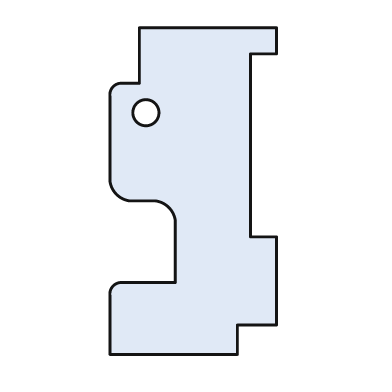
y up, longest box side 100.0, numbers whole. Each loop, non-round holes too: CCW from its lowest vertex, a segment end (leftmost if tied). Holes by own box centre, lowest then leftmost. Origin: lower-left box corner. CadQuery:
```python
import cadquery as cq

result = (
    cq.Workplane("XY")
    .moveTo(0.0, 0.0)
    .lineTo(39.0, 0.0)
    .lineTo(39.0, 9.0)
    .lineTo(51.0, 9.0)
    .lineTo(51.0, 36.0)
    .lineTo(43.0, 36.0)
    .lineTo(43.0, 92.0)
    .lineTo(51.0, 92.0)
    .lineTo(51.0, 100.0)
    .lineTo(9.0, 100.0)
    .lineTo(9.0, 83.0)
    .lineTo(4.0, 83.0)
    .threePointArc((1.0, 82.0), (0.0, 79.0))
    .lineTo(0.0, 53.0)
    .threePointArc((2.0, 49.0), (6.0, 47.0))
    .lineTo(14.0, 47.0)
    .threePointArc((18.0, 45.0), (20.0, 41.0))
    .lineTo(20.0, 22.0)
    .lineTo(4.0, 22.0)
    .threePointArc((1.0, 21.0), (0.0, 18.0))
    .close()
    .moveTo(11.0, 74.0)
    .circle(4.0)
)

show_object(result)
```